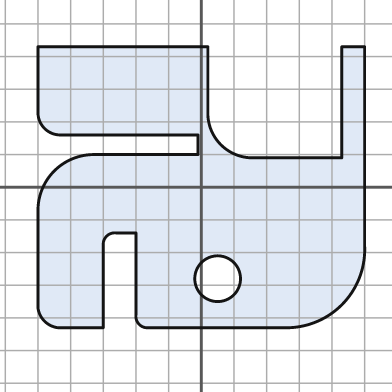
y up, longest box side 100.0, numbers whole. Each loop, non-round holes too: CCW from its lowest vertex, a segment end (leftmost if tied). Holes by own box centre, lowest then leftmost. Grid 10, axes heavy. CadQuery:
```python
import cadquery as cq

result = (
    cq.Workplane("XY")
    .moveTo(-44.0, -43.0)
    .lineTo(-30.0, -43.0)
    .lineTo(-30.0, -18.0)
    .threePointArc((-29.0, -15.0), (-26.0, -14.0))
    .lineTo(-20.0, -14.0)
    .lineTo(-20.0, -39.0)
    .threePointArc((-19.0, -42.0), (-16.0, -43.0))
    .lineTo(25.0, -43.0)
    .threePointArc((43.0, -36.0), (50.0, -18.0))
    .lineTo(50.0, 43.0)
    .lineTo(43.0, 43.0)
    .lineTo(43.0, 9.0)
    .lineTo(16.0, 9.0)
    .threePointArc((6.0, 13.0), (2.0, 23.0))
    .lineTo(2.0, 43.0)
    .lineTo(-50.0, 43.0)
    .lineTo(-50.0, 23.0)
    .threePointArc((-48.0, 18.0), (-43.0, 16.0))
    .lineTo(-1.0, 16.0)
    .lineTo(-1.0, 10.0)
    .lineTo(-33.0, 10.0)
    .threePointArc((-45.0, 5.0), (-50.0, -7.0))
    .lineTo(-50.0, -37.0)
    .threePointArc((-48.0, -41.0), (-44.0, -43.0))
    .close()
    .moveTo(5.0, -28.0)
    .circle(7.0)
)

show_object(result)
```